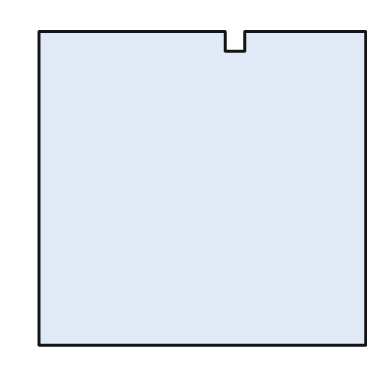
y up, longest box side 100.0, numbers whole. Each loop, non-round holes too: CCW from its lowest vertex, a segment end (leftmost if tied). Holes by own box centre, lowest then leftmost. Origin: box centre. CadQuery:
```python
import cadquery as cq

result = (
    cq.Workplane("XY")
    .moveTo(-50.0, -48.0)
    .lineTo(50.0, -48.0)
    .lineTo(50.0, 48.0)
    .lineTo(13.0, 48.0)
    .lineTo(13.0, 42.0)
    .lineTo(7.0, 42.0)
    .lineTo(7.0, 48.0)
    .lineTo(-50.0, 48.0)
    .close()
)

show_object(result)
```